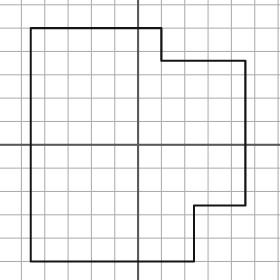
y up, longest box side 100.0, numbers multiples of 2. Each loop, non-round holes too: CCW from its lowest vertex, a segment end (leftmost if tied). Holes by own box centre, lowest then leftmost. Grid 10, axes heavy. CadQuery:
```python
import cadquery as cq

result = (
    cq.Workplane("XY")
    .moveTo(-46.0, -50.0)
    .lineTo(24.0, -50.0)
    .lineTo(24.0, -26.0)
    .lineTo(46.0, -26.0)
    .lineTo(46.0, 36.0)
    .lineTo(10.0, 36.0)
    .lineTo(10.0, 50.0)
    .lineTo(-46.0, 50.0)
    .close()
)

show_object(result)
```